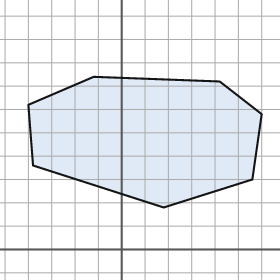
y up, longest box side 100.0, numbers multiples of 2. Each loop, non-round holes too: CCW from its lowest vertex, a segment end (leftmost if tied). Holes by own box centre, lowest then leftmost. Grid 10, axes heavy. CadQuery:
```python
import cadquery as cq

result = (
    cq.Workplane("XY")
    .moveTo(18.0, 18.0)
    .lineTo(56.0, 30.0)
    .lineTo(60.0, 58.0)
    .lineTo(42.0, 72.0)
    .lineTo(-12.0, 74.0)
    .lineTo(-40.0, 62.0)
    .lineTo(-38.0, 36.0)
    .close()
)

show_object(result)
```